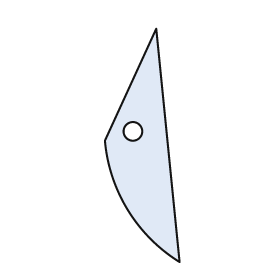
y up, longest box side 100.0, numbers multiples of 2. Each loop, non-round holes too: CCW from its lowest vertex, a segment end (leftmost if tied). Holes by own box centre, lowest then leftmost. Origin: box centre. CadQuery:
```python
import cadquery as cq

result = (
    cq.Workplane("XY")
    .moveTo(16.0, -50.0)
    .lineTo(6.0, 50.0)
    .lineTo(-16.0, 2.0)
    .threePointArc((-6.0, -28.0), (16.0, -50.0))
    .close()
    .moveTo(-4.0, 6.0)
    .circle(4.0)
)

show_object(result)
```